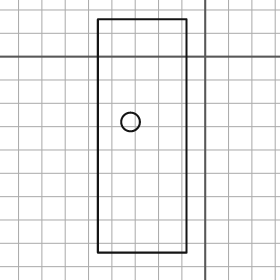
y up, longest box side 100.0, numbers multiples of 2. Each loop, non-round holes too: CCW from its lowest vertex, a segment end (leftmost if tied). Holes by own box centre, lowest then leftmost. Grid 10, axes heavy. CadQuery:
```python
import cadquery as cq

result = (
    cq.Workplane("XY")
    .moveTo(-46.0, -84.0)
    .lineTo(-8.0, -84.0)
    .lineTo(-8.0, 16.0)
    .lineTo(-46.0, 16.0)
    .close()
    .moveTo(-32.0, -28.0)
    .circle(4.0)
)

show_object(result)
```